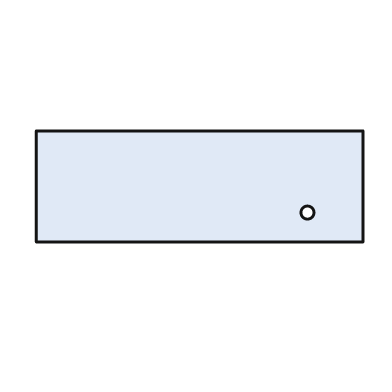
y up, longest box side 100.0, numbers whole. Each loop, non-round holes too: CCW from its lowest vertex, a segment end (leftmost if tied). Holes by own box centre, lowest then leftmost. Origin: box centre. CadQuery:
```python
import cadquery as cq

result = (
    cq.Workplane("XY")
    .moveTo(-50.0, -17.0)
    .lineTo(50.0, -17.0)
    .lineTo(50.0, 17.0)
    .lineTo(-50.0, 17.0)
    .close()
    .moveTo(33.0, -8.0)
    .circle(2.0)
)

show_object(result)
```